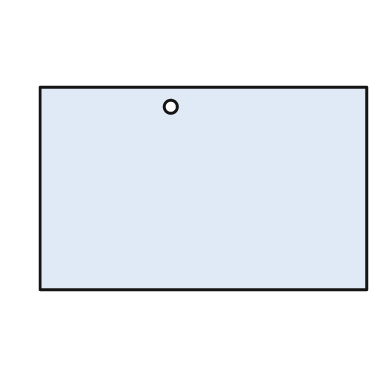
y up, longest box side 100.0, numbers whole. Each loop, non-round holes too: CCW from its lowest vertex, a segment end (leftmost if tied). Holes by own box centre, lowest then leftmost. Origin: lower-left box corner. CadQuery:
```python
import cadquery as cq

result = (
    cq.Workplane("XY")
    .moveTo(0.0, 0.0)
    .lineTo(100.0, 0.0)
    .lineTo(100.0, 62.0)
    .lineTo(0.0, 62.0)
    .close()
    .moveTo(40.0, 56.0)
    .circle(2.0)
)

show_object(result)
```